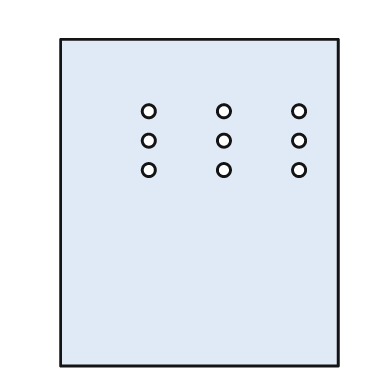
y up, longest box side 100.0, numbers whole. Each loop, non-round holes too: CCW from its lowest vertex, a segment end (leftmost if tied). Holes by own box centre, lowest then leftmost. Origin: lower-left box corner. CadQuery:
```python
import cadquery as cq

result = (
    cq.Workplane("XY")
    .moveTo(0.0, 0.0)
    .lineTo(85.0, 0.0)
    .lineTo(85.0, 100.0)
    .lineTo(0.0, 100.0)
    .close()
    .moveTo(27.0, 60.0)
    .circle(2.0)
    .moveTo(50.0, 60.0)
    .circle(2.0)
    .moveTo(73.0, 60.0)
    .circle(2.0)
    .moveTo(27.0, 69.0)
    .circle(2.0)
    .moveTo(50.0, 69.0)
    .circle(2.0)
    .moveTo(73.0, 69.0)
    .circle(2.0)
    .moveTo(27.0, 78.0)
    .circle(2.0)
    .moveTo(50.0, 78.0)
    .circle(2.0)
    .moveTo(73.0, 78.0)
    .circle(2.0)
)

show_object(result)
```